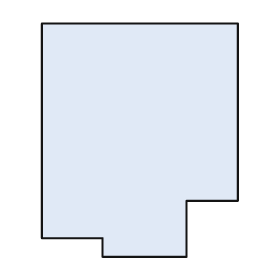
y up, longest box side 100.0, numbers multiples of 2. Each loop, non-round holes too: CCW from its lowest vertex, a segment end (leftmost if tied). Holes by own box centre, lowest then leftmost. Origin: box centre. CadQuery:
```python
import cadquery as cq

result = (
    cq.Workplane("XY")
    .moveTo(-16.0, -50.0)
    .lineTo(20.0, -50.0)
    .lineTo(20.0, -26.0)
    .lineTo(42.0, -26.0)
    .lineTo(42.0, 50.0)
    .lineTo(-42.0, 50.0)
    .lineTo(-42.0, -42.0)
    .lineTo(-16.0, -42.0)
    .close()
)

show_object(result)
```